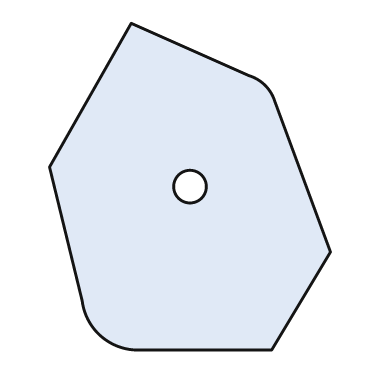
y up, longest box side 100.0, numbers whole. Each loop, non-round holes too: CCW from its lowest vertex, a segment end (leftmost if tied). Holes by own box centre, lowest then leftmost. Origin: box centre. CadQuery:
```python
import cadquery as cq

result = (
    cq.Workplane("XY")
    .moveTo(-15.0, -50.0)
    .lineTo(25.0, -50.0)
    .lineTo(43.0, -20.0)
    .lineTo(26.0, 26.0)
    .threePointArc((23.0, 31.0), (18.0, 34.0))
    .lineTo(-18.0, 50.0)
    .lineTo(-43.0, 6.0)
    .lineTo(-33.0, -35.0)
    .threePointArc((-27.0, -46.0), (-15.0, -50.0))
    .close()
    .moveTo(0.0, 0.0)
    .circle(5.0)
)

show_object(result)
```